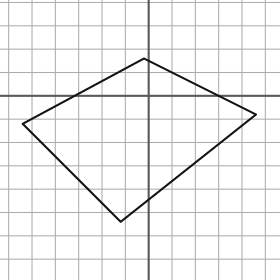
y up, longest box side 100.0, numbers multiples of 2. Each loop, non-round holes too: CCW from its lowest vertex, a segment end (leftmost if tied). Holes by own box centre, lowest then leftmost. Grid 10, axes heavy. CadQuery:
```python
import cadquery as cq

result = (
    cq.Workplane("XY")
    .moveTo(-12.0, -54.0)
    .lineTo(46.0, -8.0)
    .lineTo(-2.0, 16.0)
    .lineTo(-54.0, -12.0)
    .close()
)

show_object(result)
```